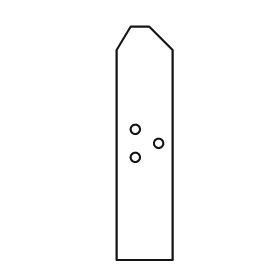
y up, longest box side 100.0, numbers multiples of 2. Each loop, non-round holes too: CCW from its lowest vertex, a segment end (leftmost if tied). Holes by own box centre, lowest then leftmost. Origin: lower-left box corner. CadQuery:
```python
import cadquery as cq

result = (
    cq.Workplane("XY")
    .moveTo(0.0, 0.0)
    .lineTo(24.0, 0.0)
    .lineTo(24.0, 90.0)
    .lineTo(14.0, 100.0)
    .lineTo(6.0, 100.0)
    .lineTo(0.0, 90.0)
    .close()
    .moveTo(8.0, 44.0)
    .circle(2.0)
    .moveTo(18.0, 50.0)
    .circle(2.0)
    .moveTo(8.0, 56.0)
    .circle(2.0)
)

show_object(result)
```